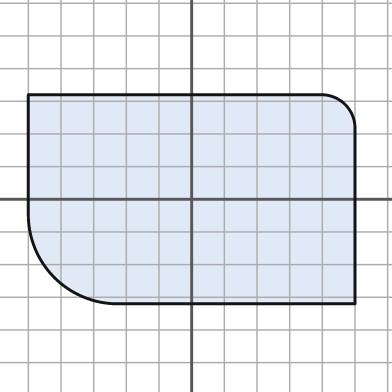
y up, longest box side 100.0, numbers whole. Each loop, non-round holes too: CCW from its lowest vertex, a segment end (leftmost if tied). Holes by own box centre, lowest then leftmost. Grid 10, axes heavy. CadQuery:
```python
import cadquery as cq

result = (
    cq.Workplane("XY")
    .moveTo(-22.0, -32.0)
    .lineTo(50.0, -32.0)
    .lineTo(50.0, 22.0)
    .threePointArc((47.0, 29.0), (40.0, 32.0))
    .lineTo(-50.0, 32.0)
    .lineTo(-50.0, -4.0)
    .threePointArc((-42.0, -24.0), (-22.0, -32.0))
    .close()
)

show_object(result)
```